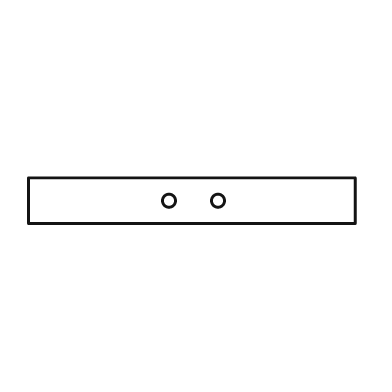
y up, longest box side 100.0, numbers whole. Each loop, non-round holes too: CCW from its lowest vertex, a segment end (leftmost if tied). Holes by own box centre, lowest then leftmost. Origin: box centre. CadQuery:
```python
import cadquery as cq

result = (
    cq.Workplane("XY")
    .moveTo(-50.0, -7.0)
    .lineTo(50.0, -7.0)
    .lineTo(50.0, 7.0)
    .lineTo(-50.0, 7.0)
    .close()
    .moveTo(-7.0, 0.0)
    .circle(2.0)
    .moveTo(8.0, 0.0)
    .circle(2.0)
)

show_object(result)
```